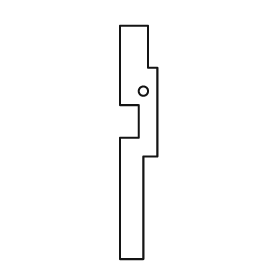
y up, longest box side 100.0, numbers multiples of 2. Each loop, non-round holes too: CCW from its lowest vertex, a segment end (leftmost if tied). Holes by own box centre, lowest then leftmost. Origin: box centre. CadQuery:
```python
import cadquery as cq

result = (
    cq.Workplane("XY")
    .moveTo(-8.0, -50.0)
    .lineTo(2.0, -50.0)
    .lineTo(2.0, -6.0)
    .lineTo(8.0, -6.0)
    .lineTo(8.0, 32.0)
    .lineTo(4.0, 32.0)
    .lineTo(4.0, 50.0)
    .lineTo(-8.0, 50.0)
    .lineTo(-8.0, 16.0)
    .lineTo(0.0, 16.0)
    .lineTo(0.0, 2.0)
    .lineTo(-8.0, 2.0)
    .close()
    .moveTo(2.0, 22.0)
    .circle(2.0)
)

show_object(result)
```